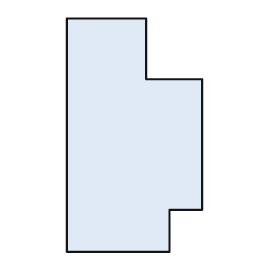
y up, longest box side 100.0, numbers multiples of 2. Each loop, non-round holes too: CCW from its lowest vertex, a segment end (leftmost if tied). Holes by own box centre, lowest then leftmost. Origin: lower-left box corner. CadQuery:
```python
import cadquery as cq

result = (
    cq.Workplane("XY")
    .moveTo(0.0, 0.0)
    .lineTo(44.0, 0.0)
    .lineTo(44.0, 18.0)
    .lineTo(58.0, 18.0)
    .lineTo(58.0, 74.0)
    .lineTo(34.0, 74.0)
    .lineTo(34.0, 100.0)
    .lineTo(0.0, 100.0)
    .close()
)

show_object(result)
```